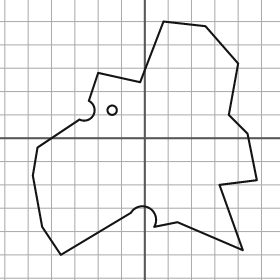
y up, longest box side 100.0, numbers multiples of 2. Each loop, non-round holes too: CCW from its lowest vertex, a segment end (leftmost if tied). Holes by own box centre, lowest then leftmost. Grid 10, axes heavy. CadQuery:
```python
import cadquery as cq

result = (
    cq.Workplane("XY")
    .moveTo(-36.0, -50.0)
    .lineTo(-6.0, -32.0)
    .threePointArc((2.0, -30.0), (4.0, -38.0))
    .lineTo(14.0, -36.0)
    .lineTo(42.0, -48.0)
    .lineTo(32.0, -20.0)
    .lineTo(48.0, -18.0)
    .lineTo(44.0, 2.0)
    .lineTo(36.0, 10.0)
    .lineTo(40.0, 32.0)
    .lineTo(26.0, 48.0)
    .lineTo(8.0, 50.0)
    .lineTo(-2.0, 24.0)
    .lineTo(-20.0, 28.0)
    .lineTo(-24.0, 16.0)
    .threePointArc((-22.0, 10.0), (-28.0, 8.0))
    .lineTo(-46.0, -4.0)
    .lineTo(-48.0, -16.0)
    .lineTo(-44.0, -38.0)
    .close()
    .moveTo(-14.0, 12.0)
    .circle(2.0)
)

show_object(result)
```